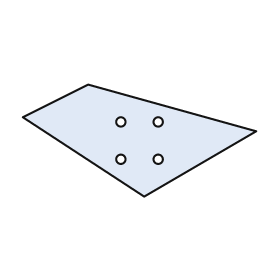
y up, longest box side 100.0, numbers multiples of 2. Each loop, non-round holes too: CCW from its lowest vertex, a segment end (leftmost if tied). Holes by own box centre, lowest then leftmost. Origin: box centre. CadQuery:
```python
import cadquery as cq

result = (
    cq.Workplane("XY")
    .moveTo(2.0, -24.0)
    .lineTo(50.0, 4.0)
    .lineTo(-22.0, 24.0)
    .lineTo(-50.0, 10.0)
    .close()
    .moveTo(-8.0, -8.0)
    .circle(2.0)
    .moveTo(8.0, -8.0)
    .circle(2.0)
    .moveTo(-8.0, 8.0)
    .circle(2.0)
    .moveTo(8.0, 8.0)
    .circle(2.0)
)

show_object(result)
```